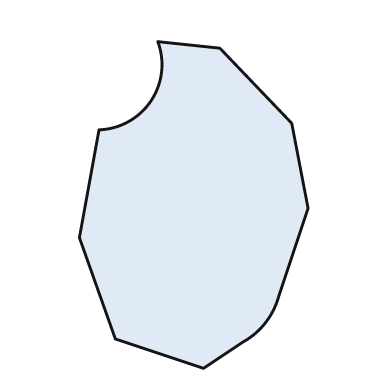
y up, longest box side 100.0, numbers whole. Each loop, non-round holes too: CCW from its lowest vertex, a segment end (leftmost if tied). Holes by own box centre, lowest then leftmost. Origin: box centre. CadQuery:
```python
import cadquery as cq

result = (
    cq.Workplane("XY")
    .moveTo(3.0, -50.0)
    .lineTo(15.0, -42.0)
    .threePointArc((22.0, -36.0), (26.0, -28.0))
    .lineTo(35.0, -1.0)
    .lineTo(30.0, 25.0)
    .lineTo(8.0, 48.0)
    .lineTo(-11.0, 50.0)
    .threePointArc((-13.0, 32.0), (-29.0, 23.0))
    .lineTo(-35.0, -10.0)
    .lineTo(-24.0, -41.0)
    .close()
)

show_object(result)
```